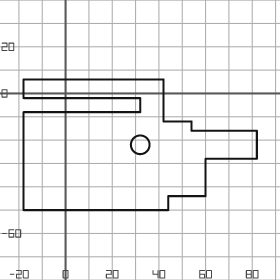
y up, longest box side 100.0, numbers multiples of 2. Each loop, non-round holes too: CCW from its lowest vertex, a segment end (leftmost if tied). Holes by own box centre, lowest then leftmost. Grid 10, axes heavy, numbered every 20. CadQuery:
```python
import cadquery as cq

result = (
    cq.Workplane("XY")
    .moveTo(-18.0, -50.0)
    .lineTo(44.0, -50.0)
    .lineTo(44.0, -44.0)
    .lineTo(60.0, -44.0)
    .lineTo(60.0, -28.0)
    .lineTo(82.0, -28.0)
    .lineTo(82.0, -16.0)
    .lineTo(54.0, -16.0)
    .lineTo(54.0, -12.0)
    .lineTo(42.0, -12.0)
    .lineTo(42.0, 6.0)
    .lineTo(-18.0, 6.0)
    .lineTo(-18.0, -2.0)
    .lineTo(32.0, -2.0)
    .lineTo(32.0, -8.0)
    .lineTo(-18.0, -8.0)
    .close()
    .moveTo(32.0, -22.0)
    .circle(4.0)
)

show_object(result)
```